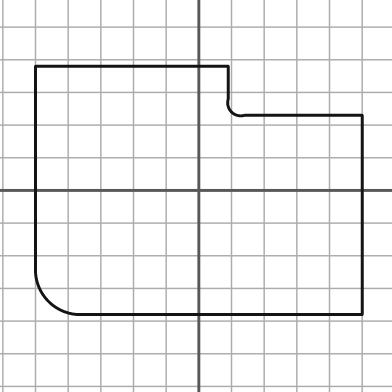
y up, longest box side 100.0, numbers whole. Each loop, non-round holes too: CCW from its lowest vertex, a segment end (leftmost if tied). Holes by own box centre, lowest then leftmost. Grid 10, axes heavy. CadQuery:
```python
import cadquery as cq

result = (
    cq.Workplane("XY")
    .moveTo(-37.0, -38.0)
    .lineTo(50.0, -38.0)
    .lineTo(50.0, 23.0)
    .lineTo(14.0, 23.0)
    .threePointArc((10.0, 24.0), (9.0, 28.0))
    .lineTo(9.0, 38.0)
    .lineTo(-50.0, 38.0)
    .lineTo(-50.0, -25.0)
    .threePointArc((-46.0, -34.0), (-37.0, -38.0))
    .close()
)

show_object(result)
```